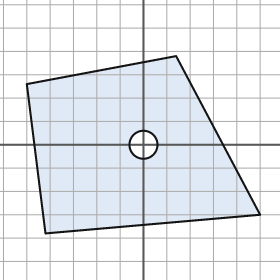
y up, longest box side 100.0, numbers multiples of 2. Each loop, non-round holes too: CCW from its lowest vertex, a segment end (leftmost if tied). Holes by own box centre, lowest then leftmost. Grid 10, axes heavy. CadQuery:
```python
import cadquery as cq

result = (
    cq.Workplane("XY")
    .moveTo(-42.0, -38.0)
    .lineTo(50.0, -30.0)
    .lineTo(14.0, 38.0)
    .lineTo(-50.0, 26.0)
    .close()
    .moveTo(0.0, 0.0)
    .circle(6.0)
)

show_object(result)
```